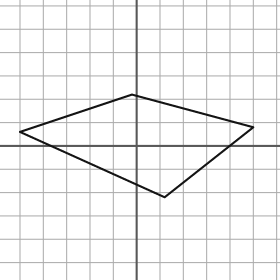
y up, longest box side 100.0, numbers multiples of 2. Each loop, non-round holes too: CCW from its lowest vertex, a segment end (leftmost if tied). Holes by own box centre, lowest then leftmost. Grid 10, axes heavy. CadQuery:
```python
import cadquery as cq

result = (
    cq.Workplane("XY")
    .moveTo(12.0, -22.0)
    .lineTo(50.0, 8.0)
    .lineTo(-2.0, 22.0)
    .lineTo(-50.0, 6.0)
    .close()
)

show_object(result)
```